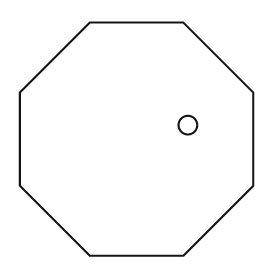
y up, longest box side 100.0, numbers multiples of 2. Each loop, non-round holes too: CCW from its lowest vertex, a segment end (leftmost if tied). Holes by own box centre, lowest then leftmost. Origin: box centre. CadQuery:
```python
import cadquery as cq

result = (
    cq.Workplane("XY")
    .moveTo(-20.0, -50.0)
    .lineTo(20.0, -50.0)
    .lineTo(50.0, -20.0)
    .lineTo(50.0, 20.0)
    .lineTo(20.0, 50.0)
    .lineTo(-20.0, 50.0)
    .lineTo(-50.0, 20.0)
    .lineTo(-50.0, -20.0)
    .close()
    .moveTo(22.0, 6.0)
    .circle(4.0)
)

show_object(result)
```